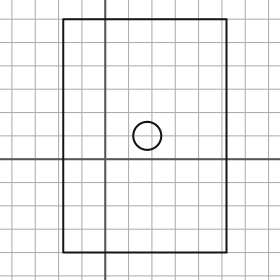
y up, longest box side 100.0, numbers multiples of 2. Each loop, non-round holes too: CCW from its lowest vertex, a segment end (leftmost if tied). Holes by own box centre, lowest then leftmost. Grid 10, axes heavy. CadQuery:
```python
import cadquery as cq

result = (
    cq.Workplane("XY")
    .moveTo(-18.0, -40.0)
    .lineTo(52.0, -40.0)
    .lineTo(52.0, 60.0)
    .lineTo(-18.0, 60.0)
    .close()
    .moveTo(18.0, 10.0)
    .circle(6.0)
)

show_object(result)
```